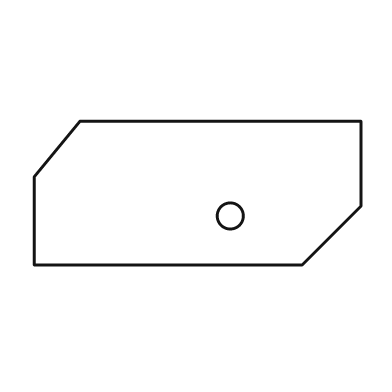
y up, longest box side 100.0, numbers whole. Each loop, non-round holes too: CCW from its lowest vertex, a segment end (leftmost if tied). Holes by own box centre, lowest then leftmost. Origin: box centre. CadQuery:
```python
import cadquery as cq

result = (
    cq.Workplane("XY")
    .moveTo(-50.0, -22.0)
    .lineTo(32.0, -22.0)
    .lineTo(50.0, -4.0)
    .lineTo(50.0, 22.0)
    .lineTo(-36.0, 22.0)
    .lineTo(-50.0, 5.0)
    .close()
    .moveTo(10.0, -7.0)
    .circle(4.0)
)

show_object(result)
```